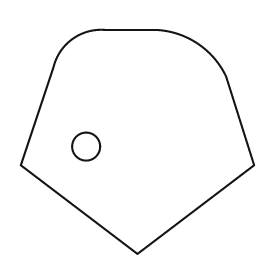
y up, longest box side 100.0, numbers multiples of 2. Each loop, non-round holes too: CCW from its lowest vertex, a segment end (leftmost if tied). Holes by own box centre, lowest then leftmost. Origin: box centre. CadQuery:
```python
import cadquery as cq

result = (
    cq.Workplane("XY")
    .moveTo(0.0, -48.0)
    .lineTo(50.0, -10.0)
    .lineTo(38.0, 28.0)
    .threePointArc((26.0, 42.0), (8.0, 48.0))
    .lineTo(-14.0, 48.0)
    .threePointArc((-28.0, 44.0), (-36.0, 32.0))
    .lineTo(-50.0, -10.0)
    .close()
    .moveTo(-22.0, -2.0)
    .circle(6.0)
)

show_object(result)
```